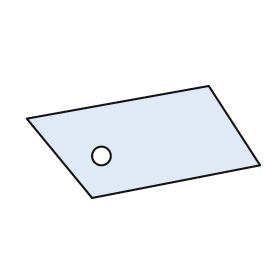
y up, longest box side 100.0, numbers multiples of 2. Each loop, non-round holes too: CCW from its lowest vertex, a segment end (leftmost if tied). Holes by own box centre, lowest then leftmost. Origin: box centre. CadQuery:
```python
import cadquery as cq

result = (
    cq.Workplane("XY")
    .moveTo(-22.0, -24.0)
    .lineTo(50.0, -10.0)
    .lineTo(28.0, 24.0)
    .lineTo(-50.0, 10.0)
    .close()
    .moveTo(-18.0, -6.0)
    .circle(4.0)
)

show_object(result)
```